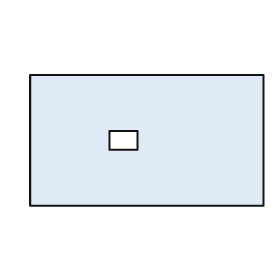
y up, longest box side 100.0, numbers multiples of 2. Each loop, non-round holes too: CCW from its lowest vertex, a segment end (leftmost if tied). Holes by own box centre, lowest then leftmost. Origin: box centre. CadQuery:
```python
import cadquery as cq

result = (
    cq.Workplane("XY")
    .moveTo(-50.0, -28.0)
    .lineTo(50.0, -28.0)
    .lineTo(50.0, 28.0)
    .lineTo(-50.0, 28.0)
    .close()
    .moveTo(-16.0, -4.0)
    .lineTo(-4.0, -4.0)
    .lineTo(-4.0, 4.0)
    .lineTo(-16.0, 4.0)
    .close()
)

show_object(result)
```